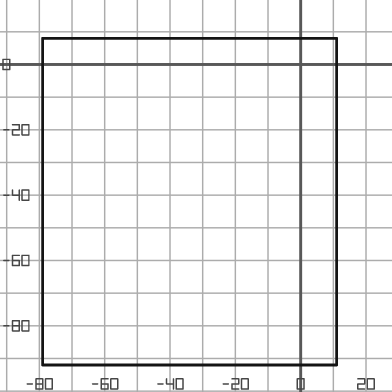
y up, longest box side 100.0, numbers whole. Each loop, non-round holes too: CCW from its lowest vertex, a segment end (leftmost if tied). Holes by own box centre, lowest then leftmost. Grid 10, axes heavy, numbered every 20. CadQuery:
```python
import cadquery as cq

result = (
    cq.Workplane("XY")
    .moveTo(-79.0, -92.0)
    .lineTo(11.0, -92.0)
    .lineTo(11.0, 8.0)
    .lineTo(-79.0, 8.0)
    .close()
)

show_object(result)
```